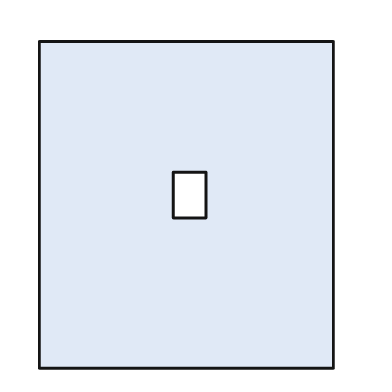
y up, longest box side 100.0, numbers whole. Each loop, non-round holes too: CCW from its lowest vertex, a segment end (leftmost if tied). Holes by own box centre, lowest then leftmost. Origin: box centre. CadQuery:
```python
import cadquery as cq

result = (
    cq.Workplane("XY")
    .moveTo(-45.0, -50.0)
    .lineTo(45.0, -50.0)
    .lineTo(45.0, 50.0)
    .lineTo(-45.0, 50.0)
    .close()
    .moveTo(-4.0, -4.0)
    .lineTo(6.0, -4.0)
    .lineTo(6.0, 10.0)
    .lineTo(-4.0, 10.0)
    .close()
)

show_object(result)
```